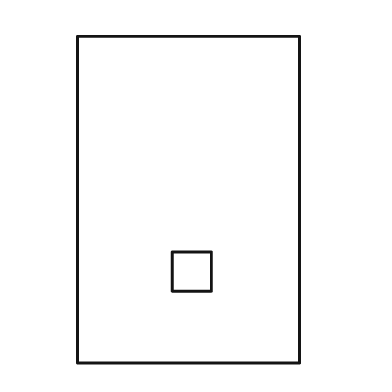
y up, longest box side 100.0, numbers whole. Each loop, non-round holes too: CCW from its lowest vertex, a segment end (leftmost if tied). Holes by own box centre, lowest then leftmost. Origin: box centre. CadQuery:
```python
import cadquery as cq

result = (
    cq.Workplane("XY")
    .moveTo(-34.0, -50.0)
    .lineTo(34.0, -50.0)
    .lineTo(34.0, 50.0)
    .lineTo(-34.0, 50.0)
    .close()
    .moveTo(-5.0, -28.0)
    .lineTo(7.0, -28.0)
    .lineTo(7.0, -16.0)
    .lineTo(-5.0, -16.0)
    .close()
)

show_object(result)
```